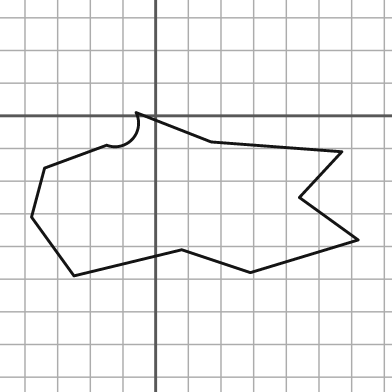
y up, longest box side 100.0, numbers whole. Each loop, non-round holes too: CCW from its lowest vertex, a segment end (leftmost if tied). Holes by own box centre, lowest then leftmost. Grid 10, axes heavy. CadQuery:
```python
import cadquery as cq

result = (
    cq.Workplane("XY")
    .moveTo(-25.0, -49.0)
    .lineTo(8.0, -41.0)
    .lineTo(29.0, -48.0)
    .lineTo(62.0, -38.0)
    .lineTo(44.0, -25.0)
    .lineTo(57.0, -11.0)
    .lineTo(17.0, -8.0)
    .lineTo(-6.0, 1.0)
    .threePointArc((-7.0, -7.0), (-15.0, -9.0))
    .lineTo(-34.0, -16.0)
    .lineTo(-38.0, -31.0)
    .close()
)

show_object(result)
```